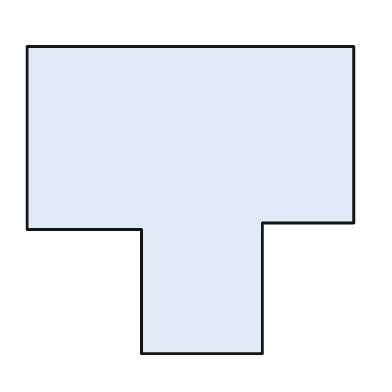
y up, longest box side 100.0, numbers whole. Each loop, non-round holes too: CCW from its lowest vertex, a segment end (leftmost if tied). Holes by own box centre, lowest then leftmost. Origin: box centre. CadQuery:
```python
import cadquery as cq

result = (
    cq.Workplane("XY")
    .moveTo(-15.0, -47.0)
    .lineTo(22.0, -47.0)
    .lineTo(22.0, -7.0)
    .lineTo(50.0, -7.0)
    .lineTo(50.0, 47.0)
    .lineTo(-50.0, 47.0)
    .lineTo(-50.0, -9.0)
    .lineTo(-15.0, -9.0)
    .close()
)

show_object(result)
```